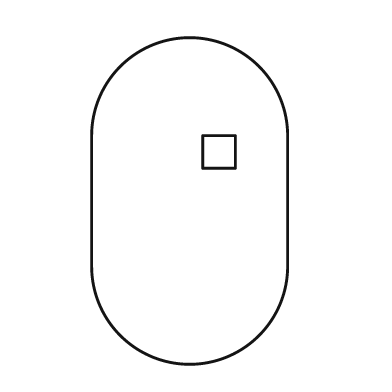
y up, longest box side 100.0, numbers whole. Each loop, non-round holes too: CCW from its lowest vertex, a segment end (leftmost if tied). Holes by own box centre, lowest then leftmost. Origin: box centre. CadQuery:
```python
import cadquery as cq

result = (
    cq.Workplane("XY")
    .moveTo(-30.0, -20.0)
    .threePointArc((0.0, -50.0), (30.0, -20.0))
    .lineTo(30.0, 20.0)
    .threePointArc((0.0, 50.0), (-30.0, 20.0))
    .close()
    .moveTo(4.0, 10.0)
    .lineTo(14.0, 10.0)
    .lineTo(14.0, 20.0)
    .lineTo(4.0, 20.0)
    .close()
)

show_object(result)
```